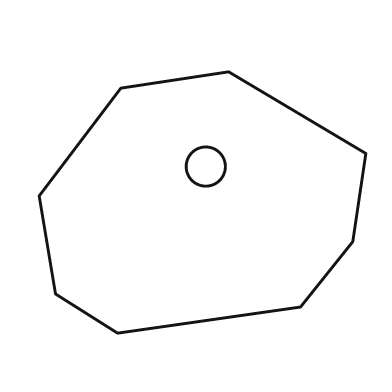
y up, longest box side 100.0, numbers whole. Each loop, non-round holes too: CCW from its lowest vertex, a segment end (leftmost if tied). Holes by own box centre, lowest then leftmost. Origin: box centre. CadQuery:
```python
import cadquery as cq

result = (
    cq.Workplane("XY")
    .moveTo(-26.0, -40.0)
    .lineTo(30.0, -32.0)
    .lineTo(46.0, -12.0)
    .lineTo(50.0, 15.0)
    .lineTo(8.0, 40.0)
    .lineTo(-25.0, 35.0)
    .lineTo(-50.0, 2.0)
    .lineTo(-45.0, -28.0)
    .close()
    .moveTo(1.0, 11.0)
    .circle(6.0)
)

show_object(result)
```